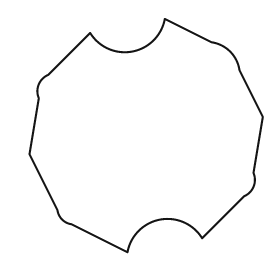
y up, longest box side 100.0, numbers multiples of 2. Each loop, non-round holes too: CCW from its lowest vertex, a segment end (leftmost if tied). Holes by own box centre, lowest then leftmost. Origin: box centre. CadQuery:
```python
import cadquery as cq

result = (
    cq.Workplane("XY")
    .moveTo(-8.0, -50.0)
    .threePointArc((6.0, -36.0), (24.0, -44.0))
    .lineTo(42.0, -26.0)
    .threePointArc((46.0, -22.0), (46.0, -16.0))
    .lineTo(50.0, 8.0)
    .lineTo(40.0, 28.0)
    .threePointArc((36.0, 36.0), (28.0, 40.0))
    .lineTo(8.0, 50.0)
    .threePointArc((-6.0, 36.0), (-24.0, 44.0))
    .lineTo(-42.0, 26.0)
    .threePointArc((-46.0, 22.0), (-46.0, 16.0))
    .lineTo(-50.0, -8.0)
    .lineTo(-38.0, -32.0)
    .threePointArc((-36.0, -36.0), (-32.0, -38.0))
    .close()
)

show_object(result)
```